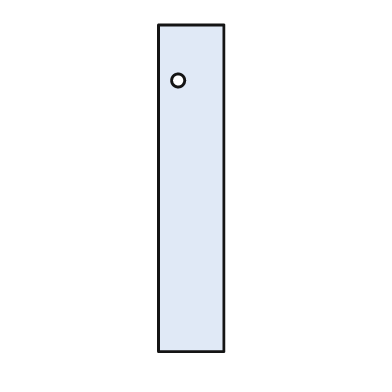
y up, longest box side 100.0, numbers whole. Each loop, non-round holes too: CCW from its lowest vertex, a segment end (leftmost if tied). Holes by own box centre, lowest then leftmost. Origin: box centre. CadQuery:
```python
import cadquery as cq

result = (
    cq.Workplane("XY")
    .moveTo(-10.0, -50.0)
    .lineTo(10.0, -50.0)
    .lineTo(10.0, 50.0)
    .lineTo(-10.0, 50.0)
    .close()
    .moveTo(-4.0, 33.0)
    .circle(2.0)
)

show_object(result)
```